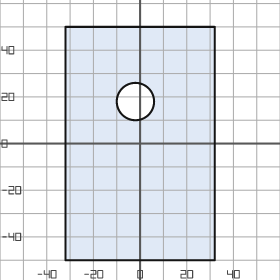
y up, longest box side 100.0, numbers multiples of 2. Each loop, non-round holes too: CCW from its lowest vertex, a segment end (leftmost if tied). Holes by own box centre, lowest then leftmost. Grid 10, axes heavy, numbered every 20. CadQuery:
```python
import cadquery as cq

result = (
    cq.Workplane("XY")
    .moveTo(-32.0, -50.0)
    .lineTo(32.0, -50.0)
    .lineTo(32.0, 50.0)
    .lineTo(-32.0, 50.0)
    .close()
    .moveTo(-2.0, 18.0)
    .circle(8.0)
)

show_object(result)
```